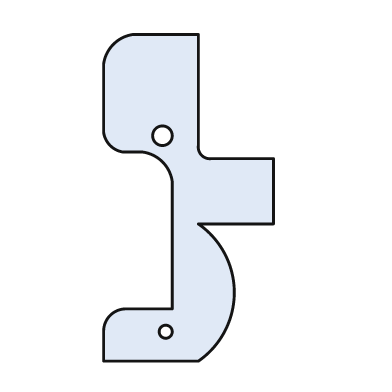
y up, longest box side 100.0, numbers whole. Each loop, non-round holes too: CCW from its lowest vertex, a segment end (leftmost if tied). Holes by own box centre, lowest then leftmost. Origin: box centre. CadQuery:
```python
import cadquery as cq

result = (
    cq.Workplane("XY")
    .moveTo(-26.0, -50.0)
    .lineTo(3.0, -50.0)
    .threePointArc((14.0, -29.0), (3.0, -8.0))
    .lineTo(26.0, -8.0)
    .lineTo(26.0, 12.0)
    .lineTo(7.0, 12.0)
    .threePointArc((4.0, 13.0), (3.0, 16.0))
    .lineTo(3.0, 50.0)
    .lineTo(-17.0, 50.0)
    .threePointArc((-23.0, 47.0), (-26.0, 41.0))
    .lineTo(-26.0, 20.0)
    .threePointArc((-24.0, 16.0), (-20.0, 14.0))
    .lineTo(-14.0, 14.0)
    .threePointArc((-8.0, 11.0), (-5.0, 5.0))
    .lineTo(-5.0, -34.0)
    .lineTo(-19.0, -34.0)
    .threePointArc((-24.0, -36.0), (-26.0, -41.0))
    .close()
    .moveTo(-7.0, -41.0)
    .circle(2.0)
    .moveTo(-8.0, 19.0)
    .circle(3.0)
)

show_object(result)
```